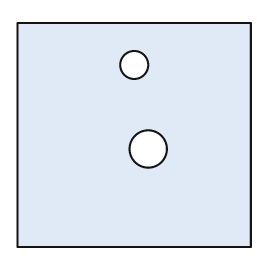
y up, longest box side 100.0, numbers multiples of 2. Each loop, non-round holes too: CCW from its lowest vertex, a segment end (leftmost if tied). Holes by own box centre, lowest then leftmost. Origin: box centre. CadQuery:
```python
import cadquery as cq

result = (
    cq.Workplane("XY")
    .moveTo(-50.0, -48.0)
    .lineTo(50.0, -48.0)
    .lineTo(50.0, 48.0)
    .lineTo(-50.0, 48.0)
    .close()
    .moveTo(6.0, -6.0)
    .circle(8.0)
    .moveTo(0.0, 30.0)
    .circle(6.0)
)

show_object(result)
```